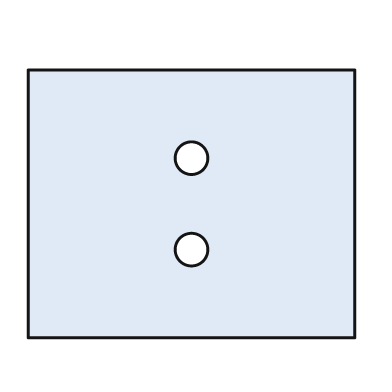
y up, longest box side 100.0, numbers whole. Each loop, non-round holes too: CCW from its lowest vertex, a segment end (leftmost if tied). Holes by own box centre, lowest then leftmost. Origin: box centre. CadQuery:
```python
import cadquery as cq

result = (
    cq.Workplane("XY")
    .moveTo(-50.0, -41.0)
    .lineTo(50.0, -41.0)
    .lineTo(50.0, 41.0)
    .lineTo(-50.0, 41.0)
    .close()
    .moveTo(0.0, -14.0)
    .circle(5.0)
    .moveTo(0.0, 14.0)
    .circle(5.0)
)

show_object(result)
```